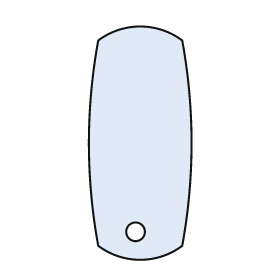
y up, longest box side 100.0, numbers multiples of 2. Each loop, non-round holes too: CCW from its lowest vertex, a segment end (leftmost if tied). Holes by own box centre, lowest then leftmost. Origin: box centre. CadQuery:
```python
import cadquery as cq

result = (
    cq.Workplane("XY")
    .moveTo(-18.0, -44.0)
    .threePointArc((0.0, -50.0), (18.0, -44.0))
    .threePointArc((22.0, 0.0), (18.0, 44.0))
    .threePointArc((0.0, 50.0), (-18.0, 44.0))
    .threePointArc((-22.0, 0.0), (-18.0, -44.0))
    .close()
    .moveTo(-2.0, -38.0)
    .circle(4.0)
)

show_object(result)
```